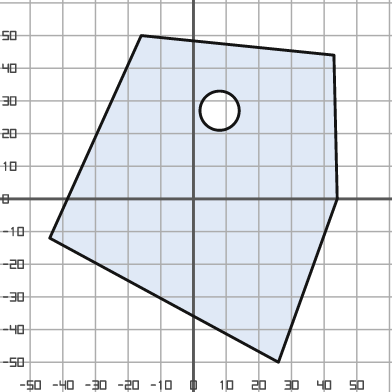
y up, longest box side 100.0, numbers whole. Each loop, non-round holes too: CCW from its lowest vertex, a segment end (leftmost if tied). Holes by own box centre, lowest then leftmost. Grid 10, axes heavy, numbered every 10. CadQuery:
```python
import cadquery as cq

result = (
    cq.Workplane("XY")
    .moveTo(26.0, -50.0)
    .lineTo(44.0, 0.0)
    .lineTo(43.0, 44.0)
    .lineTo(-16.0, 50.0)
    .lineTo(-44.0, -12.0)
    .close()
    .moveTo(8.0, 27.0)
    .circle(6.0)
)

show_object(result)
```